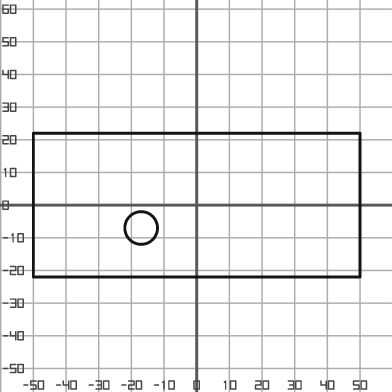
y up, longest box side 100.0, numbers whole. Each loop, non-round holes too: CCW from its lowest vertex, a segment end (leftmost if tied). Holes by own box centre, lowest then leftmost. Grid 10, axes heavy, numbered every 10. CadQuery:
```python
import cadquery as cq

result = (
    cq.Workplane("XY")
    .moveTo(-50.0, -22.0)
    .lineTo(50.0, -22.0)
    .lineTo(50.0, 22.0)
    .lineTo(-50.0, 22.0)
    .close()
    .moveTo(-17.0, -7.0)
    .circle(5.0)
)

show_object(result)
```